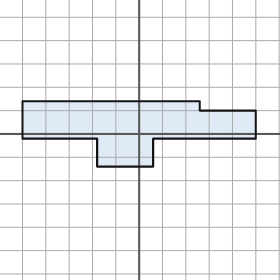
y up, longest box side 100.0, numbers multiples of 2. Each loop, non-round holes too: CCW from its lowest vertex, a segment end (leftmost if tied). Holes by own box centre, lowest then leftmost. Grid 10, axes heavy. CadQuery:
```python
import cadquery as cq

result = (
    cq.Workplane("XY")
    .moveTo(-18.0, -14.0)
    .lineTo(6.0, -14.0)
    .lineTo(6.0, -2.0)
    .lineTo(50.0, -2.0)
    .lineTo(50.0, 10.0)
    .lineTo(26.0, 10.0)
    .lineTo(26.0, 14.0)
    .lineTo(-50.0, 14.0)
    .lineTo(-50.0, -2.0)
    .lineTo(-18.0, -2.0)
    .close()
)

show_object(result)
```